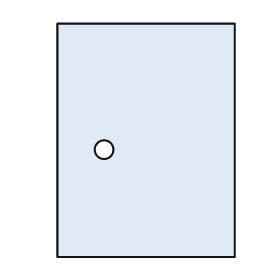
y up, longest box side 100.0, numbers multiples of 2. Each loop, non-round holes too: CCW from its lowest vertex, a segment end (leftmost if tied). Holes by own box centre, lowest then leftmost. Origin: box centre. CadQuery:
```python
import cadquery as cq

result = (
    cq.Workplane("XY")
    .moveTo(-38.0, -50.0)
    .lineTo(38.0, -50.0)
    .lineTo(38.0, 50.0)
    .lineTo(-38.0, 50.0)
    .close()
    .moveTo(-18.0, -4.0)
    .circle(4.0)
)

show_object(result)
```